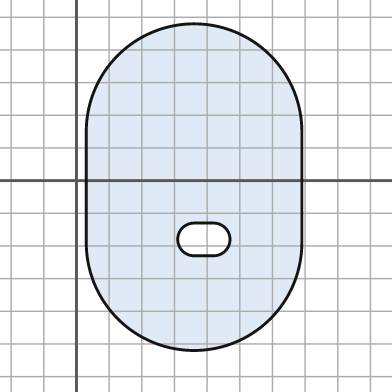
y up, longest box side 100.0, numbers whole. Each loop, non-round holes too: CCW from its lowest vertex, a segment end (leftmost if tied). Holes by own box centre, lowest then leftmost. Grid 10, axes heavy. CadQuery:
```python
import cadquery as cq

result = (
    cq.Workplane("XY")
    .moveTo(3.0, -19.0)
    .threePointArc((36.0, -52.0), (69.0, -19.0))
    .lineTo(69.0, 15.0)
    .threePointArc((36.0, 48.0), (3.0, 15.0))
    .close()
    .moveTo(36.0, -23.0)
    .lineTo(42.0, -23.0)
    .threePointArc((47.0, -18.0), (42.0, -13.0))
    .lineTo(36.0, -13.0)
    .threePointArc((31.0, -18.0), (36.0, -23.0))
    .close()
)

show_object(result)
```